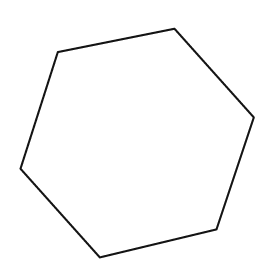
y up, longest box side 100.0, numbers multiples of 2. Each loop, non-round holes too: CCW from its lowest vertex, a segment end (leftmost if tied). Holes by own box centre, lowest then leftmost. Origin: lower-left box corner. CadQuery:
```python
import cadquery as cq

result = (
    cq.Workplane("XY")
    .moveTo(34.0, 0.0)
    .lineTo(84.0, 12.0)
    .lineTo(100.0, 60.0)
    .lineTo(66.0, 98.0)
    .lineTo(16.0, 88.0)
    .lineTo(0.0, 38.0)
    .close()
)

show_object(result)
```